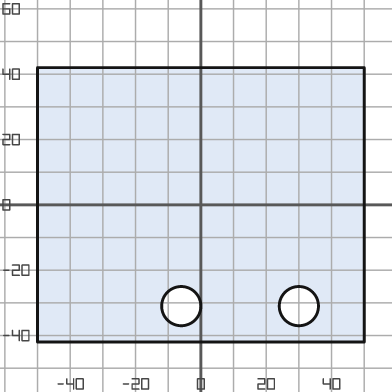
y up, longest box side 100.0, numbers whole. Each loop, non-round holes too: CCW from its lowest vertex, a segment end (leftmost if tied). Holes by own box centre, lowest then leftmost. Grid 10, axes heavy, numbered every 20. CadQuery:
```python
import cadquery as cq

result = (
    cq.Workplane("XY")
    .moveTo(-50.0, -42.0)
    .lineTo(50.0, -42.0)
    .lineTo(50.0, 42.0)
    .lineTo(-50.0, 42.0)
    .close()
    .moveTo(-6.0, -31.0)
    .circle(6.0)
    .moveTo(30.0, -31.0)
    .circle(6.0)
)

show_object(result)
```